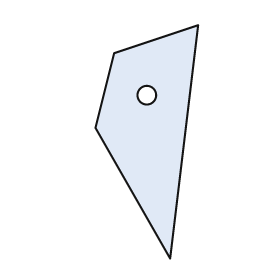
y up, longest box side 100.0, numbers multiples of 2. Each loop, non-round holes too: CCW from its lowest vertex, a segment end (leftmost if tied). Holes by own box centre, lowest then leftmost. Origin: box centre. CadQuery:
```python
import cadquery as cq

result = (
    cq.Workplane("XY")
    .moveTo(10.0, -50.0)
    .lineTo(22.0, 50.0)
    .lineTo(-14.0, 38.0)
    .lineTo(-22.0, 6.0)
    .close()
    .moveTo(0.0, 20.0)
    .circle(4.0)
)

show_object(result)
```